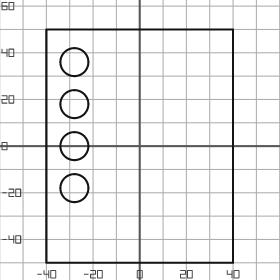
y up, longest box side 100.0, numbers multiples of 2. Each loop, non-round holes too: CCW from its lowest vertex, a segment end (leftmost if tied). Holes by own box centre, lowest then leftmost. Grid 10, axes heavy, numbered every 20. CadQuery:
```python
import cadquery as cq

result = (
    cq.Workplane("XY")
    .moveTo(-40.0, -50.0)
    .lineTo(40.0, -50.0)
    .lineTo(40.0, 50.0)
    .lineTo(-40.0, 50.0)
    .close()
    .moveTo(-28.0, -18.0)
    .circle(6.0)
    .moveTo(-28.0, 0.0)
    .circle(6.0)
    .moveTo(-28.0, 18.0)
    .circle(6.0)
    .moveTo(-28.0, 36.0)
    .circle(6.0)
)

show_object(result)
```